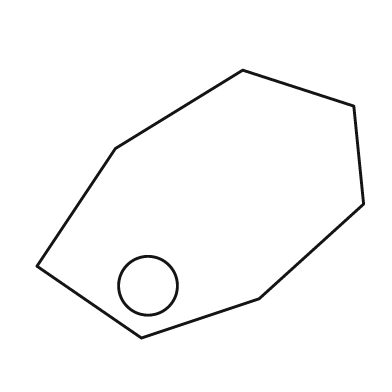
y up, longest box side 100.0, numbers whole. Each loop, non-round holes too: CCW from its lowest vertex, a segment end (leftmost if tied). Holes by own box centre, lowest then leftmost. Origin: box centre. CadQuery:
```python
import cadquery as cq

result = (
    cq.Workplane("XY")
    .moveTo(-18.0, -41.0)
    .lineTo(18.0, -29.0)
    .lineTo(50.0, 0.0)
    .lineTo(47.0, 30.0)
    .lineTo(13.0, 41.0)
    .lineTo(-26.0, 17.0)
    .lineTo(-50.0, -19.0)
    .close()
    .moveTo(-16.0, -25.0)
    .circle(9.0)
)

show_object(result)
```